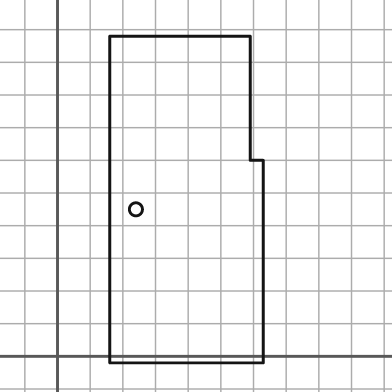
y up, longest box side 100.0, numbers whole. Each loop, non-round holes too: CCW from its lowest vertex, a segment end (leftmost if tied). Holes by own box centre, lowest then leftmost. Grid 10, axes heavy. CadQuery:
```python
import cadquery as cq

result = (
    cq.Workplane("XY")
    .moveTo(16.0, -2.0)
    .lineTo(63.0, -2.0)
    .lineTo(63.0, 60.0)
    .lineTo(59.0, 60.0)
    .lineTo(59.0, 98.0)
    .lineTo(16.0, 98.0)
    .close()
    .moveTo(24.0, 45.0)
    .circle(2.0)
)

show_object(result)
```